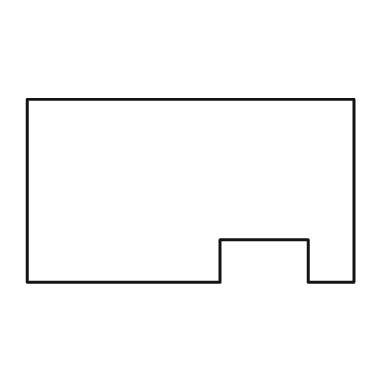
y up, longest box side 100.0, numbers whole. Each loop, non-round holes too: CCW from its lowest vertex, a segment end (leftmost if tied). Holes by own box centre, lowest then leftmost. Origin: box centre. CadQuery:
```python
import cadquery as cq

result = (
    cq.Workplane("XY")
    .moveTo(-50.0, -28.0)
    .lineTo(9.0, -28.0)
    .lineTo(9.0, -15.0)
    .lineTo(36.0, -15.0)
    .lineTo(36.0, -28.0)
    .lineTo(50.0, -28.0)
    .lineTo(50.0, 28.0)
    .lineTo(-50.0, 28.0)
    .close()
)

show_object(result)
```